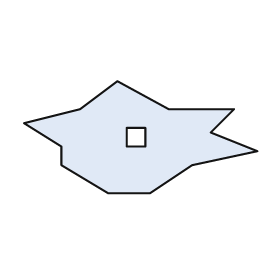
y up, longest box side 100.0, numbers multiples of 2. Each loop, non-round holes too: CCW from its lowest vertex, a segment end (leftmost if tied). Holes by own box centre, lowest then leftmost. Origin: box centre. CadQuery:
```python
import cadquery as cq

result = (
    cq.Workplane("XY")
    .moveTo(-14.0, -24.0)
    .lineTo(4.0, -24.0)
    .lineTo(22.0, -12.0)
    .lineTo(50.0, -6.0)
    .lineTo(30.0, 2.0)
    .lineTo(40.0, 12.0)
    .lineTo(12.0, 12.0)
    .lineTo(-10.0, 24.0)
    .lineTo(-26.0, 12.0)
    .lineTo(-50.0, 6.0)
    .lineTo(-34.0, -4.0)
    .lineTo(-34.0, -12.0)
    .close()
    .moveTo(-6.0, -4.0)
    .lineTo(2.0, -4.0)
    .lineTo(2.0, 4.0)
    .lineTo(-6.0, 4.0)
    .close()
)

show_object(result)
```